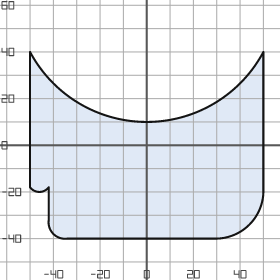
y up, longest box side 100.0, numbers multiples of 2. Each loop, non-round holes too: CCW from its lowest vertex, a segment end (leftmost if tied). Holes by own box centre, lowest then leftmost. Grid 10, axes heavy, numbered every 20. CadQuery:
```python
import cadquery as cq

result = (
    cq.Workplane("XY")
    .moveTo(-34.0, -40.0)
    .lineTo(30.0, -40.0)
    .threePointArc((44.0, -34.0), (50.0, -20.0))
    .lineTo(50.0, 40.0)
    .threePointArc((0.0, 10.0), (-50.0, 40.0))
    .lineTo(-50.0, -18.0)
    .threePointArc((-46.0, -20.0), (-42.0, -18.0))
    .lineTo(-42.0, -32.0)
    .threePointArc((-40.0, -38.0), (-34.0, -40.0))
    .close()
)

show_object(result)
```